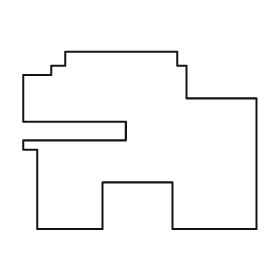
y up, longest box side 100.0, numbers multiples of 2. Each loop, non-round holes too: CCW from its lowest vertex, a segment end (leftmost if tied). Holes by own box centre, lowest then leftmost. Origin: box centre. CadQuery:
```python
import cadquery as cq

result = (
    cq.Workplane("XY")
    .moveTo(-44.0, -38.0)
    .lineTo(-16.0, -38.0)
    .lineTo(-16.0, -18.0)
    .lineTo(14.0, -18.0)
    .lineTo(14.0, -38.0)
    .lineTo(50.0, -38.0)
    .lineTo(50.0, 18.0)
    .lineTo(20.0, 18.0)
    .lineTo(20.0, 32.0)
    .lineTo(16.0, 32.0)
    .lineTo(16.0, 38.0)
    .lineTo(-32.0, 38.0)
    .lineTo(-32.0, 32.0)
    .lineTo(-38.0, 32.0)
    .lineTo(-38.0, 28.0)
    .lineTo(-50.0, 28.0)
    .lineTo(-50.0, 8.0)
    .lineTo(-6.0, 8.0)
    .lineTo(-6.0, 0.0)
    .lineTo(-50.0, 0.0)
    .lineTo(-50.0, -4.0)
    .lineTo(-44.0, -4.0)
    .close()
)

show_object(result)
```